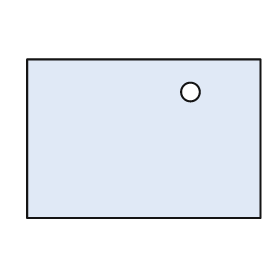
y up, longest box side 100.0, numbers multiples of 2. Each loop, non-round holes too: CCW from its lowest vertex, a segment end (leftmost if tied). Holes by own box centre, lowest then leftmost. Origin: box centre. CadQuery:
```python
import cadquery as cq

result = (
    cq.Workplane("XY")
    .moveTo(-50.0, -34.0)
    .lineTo(50.0, -34.0)
    .lineTo(50.0, 34.0)
    .lineTo(-50.0, 34.0)
    .close()
    .moveTo(20.0, 20.0)
    .circle(4.0)
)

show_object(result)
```